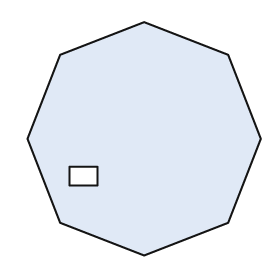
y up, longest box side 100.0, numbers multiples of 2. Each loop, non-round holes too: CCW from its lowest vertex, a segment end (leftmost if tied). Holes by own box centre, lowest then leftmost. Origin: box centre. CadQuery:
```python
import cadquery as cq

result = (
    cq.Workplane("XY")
    .moveTo(0.0, -50.0)
    .lineTo(36.0, -36.0)
    .lineTo(50.0, 0.0)
    .lineTo(36.0, 36.0)
    .lineTo(0.0, 50.0)
    .lineTo(-36.0, 36.0)
    .lineTo(-50.0, 0.0)
    .lineTo(-36.0, -36.0)
    .close()
    .moveTo(-32.0, -20.0)
    .lineTo(-20.0, -20.0)
    .lineTo(-20.0, -12.0)
    .lineTo(-32.0, -12.0)
    .close()
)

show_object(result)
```